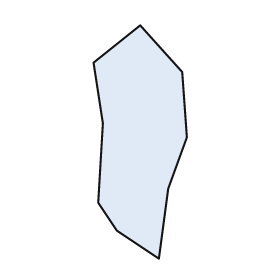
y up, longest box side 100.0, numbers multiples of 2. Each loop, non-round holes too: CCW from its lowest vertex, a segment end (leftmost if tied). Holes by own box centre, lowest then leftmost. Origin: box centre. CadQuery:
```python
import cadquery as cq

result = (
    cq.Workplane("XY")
    .moveTo(8.0, -50.0)
    .lineTo(12.0, -20.0)
    .lineTo(20.0, 2.0)
    .lineTo(18.0, 30.0)
    .lineTo(0.0, 50.0)
    .lineTo(-20.0, 34.0)
    .lineTo(-16.0, 8.0)
    .lineTo(-18.0, -26.0)
    .lineTo(-10.0, -38.0)
    .close()
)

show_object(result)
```